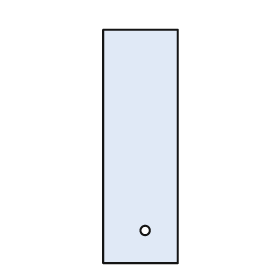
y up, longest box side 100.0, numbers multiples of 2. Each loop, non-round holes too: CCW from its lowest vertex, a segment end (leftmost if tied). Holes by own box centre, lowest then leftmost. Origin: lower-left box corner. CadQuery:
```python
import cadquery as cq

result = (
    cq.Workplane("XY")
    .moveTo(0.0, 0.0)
    .lineTo(32.0, 0.0)
    .lineTo(32.0, 100.0)
    .lineTo(0.0, 100.0)
    .close()
    .moveTo(18.0, 14.0)
    .circle(2.0)
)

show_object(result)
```